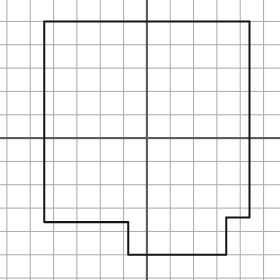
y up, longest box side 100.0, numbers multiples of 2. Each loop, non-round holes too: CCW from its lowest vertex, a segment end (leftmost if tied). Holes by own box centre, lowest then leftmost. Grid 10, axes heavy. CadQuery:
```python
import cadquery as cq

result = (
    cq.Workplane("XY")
    .moveTo(-8.0, -50.0)
    .lineTo(34.0, -50.0)
    .lineTo(34.0, -34.0)
    .lineTo(44.0, -34.0)
    .lineTo(44.0, 50.0)
    .lineTo(-44.0, 50.0)
    .lineTo(-44.0, -36.0)
    .lineTo(-8.0, -36.0)
    .close()
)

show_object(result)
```